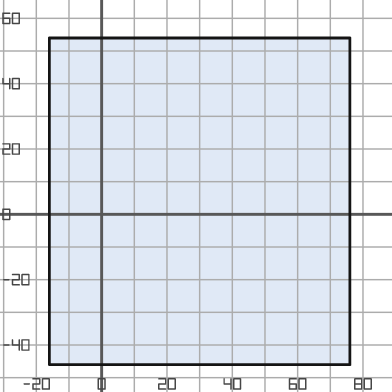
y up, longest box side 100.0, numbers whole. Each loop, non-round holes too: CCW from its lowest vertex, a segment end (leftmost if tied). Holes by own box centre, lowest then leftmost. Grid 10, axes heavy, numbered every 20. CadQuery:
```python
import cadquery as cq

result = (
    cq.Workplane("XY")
    .moveTo(-16.0, -46.0)
    .lineTo(76.0, -46.0)
    .lineTo(76.0, 54.0)
    .lineTo(-16.0, 54.0)
    .close()
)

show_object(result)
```